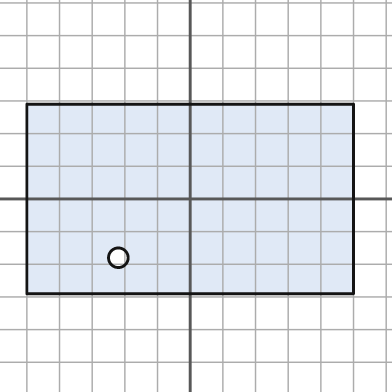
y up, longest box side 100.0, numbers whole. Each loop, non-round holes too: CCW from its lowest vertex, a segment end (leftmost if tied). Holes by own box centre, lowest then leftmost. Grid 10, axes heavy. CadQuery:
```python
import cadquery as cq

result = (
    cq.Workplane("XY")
    .moveTo(-50.0, -29.0)
    .lineTo(50.0, -29.0)
    .lineTo(50.0, 29.0)
    .lineTo(-50.0, 29.0)
    .close()
    .moveTo(-22.0, -18.0)
    .circle(3.0)
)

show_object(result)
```